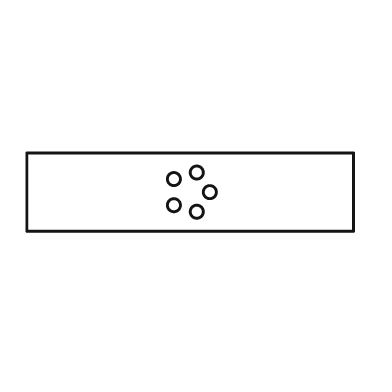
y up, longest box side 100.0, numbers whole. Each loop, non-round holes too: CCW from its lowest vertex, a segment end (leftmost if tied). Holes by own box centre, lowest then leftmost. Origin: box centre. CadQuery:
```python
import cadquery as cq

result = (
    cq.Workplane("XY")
    .moveTo(-50.0, -12.0)
    .lineTo(50.0, -12.0)
    .lineTo(50.0, 12.0)
    .lineTo(-50.0, 12.0)
    .close()
    .moveTo(2.0, -6.0)
    .circle(2.0)
    .moveTo(-5.0, -4.0)
    .circle(2.0)
    .moveTo(6.0, 0.0)
    .circle(2.0)
    .moveTo(-5.0, 4.0)
    .circle(2.0)
    .moveTo(2.0, 6.0)
    .circle(2.0)
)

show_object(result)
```